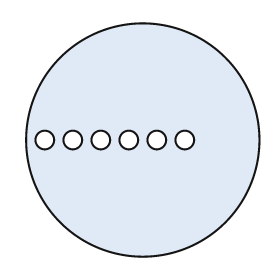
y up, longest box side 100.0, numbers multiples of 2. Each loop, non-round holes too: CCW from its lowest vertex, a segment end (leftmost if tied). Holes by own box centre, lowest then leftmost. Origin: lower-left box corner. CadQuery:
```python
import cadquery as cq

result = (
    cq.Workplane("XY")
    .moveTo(50.0, 50.0)
    .circle(50.0)
    .moveTo(8.0, 50.0)
    .circle(4.0)
    .moveTo(20.0, 50.0)
    .circle(4.0)
    .moveTo(32.0, 50.0)
    .circle(4.0)
    .moveTo(44.0, 50.0)
    .circle(4.0)
    .moveTo(56.0, 50.0)
    .circle(4.0)
    .moveTo(68.0, 50.0)
    .circle(4.0)
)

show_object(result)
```